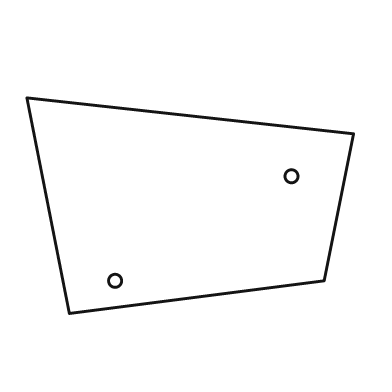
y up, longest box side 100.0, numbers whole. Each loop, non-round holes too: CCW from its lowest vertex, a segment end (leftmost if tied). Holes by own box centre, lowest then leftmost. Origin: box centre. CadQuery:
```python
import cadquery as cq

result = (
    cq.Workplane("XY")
    .moveTo(-37.0, -33.0)
    .lineTo(41.0, -23.0)
    .lineTo(50.0, 22.0)
    .lineTo(-50.0, 33.0)
    .close()
    .moveTo(-23.0, -23.0)
    .circle(2.0)
    .moveTo(31.0, 9.0)
    .circle(2.0)
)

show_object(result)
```